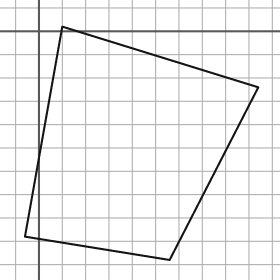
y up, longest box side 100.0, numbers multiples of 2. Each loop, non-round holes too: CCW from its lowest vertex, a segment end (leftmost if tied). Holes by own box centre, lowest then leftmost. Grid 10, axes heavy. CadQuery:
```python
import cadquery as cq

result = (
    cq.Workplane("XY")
    .moveTo(56.0, -98.0)
    .lineTo(94.0, -24.0)
    .lineTo(10.0, 2.0)
    .lineTo(-6.0, -88.0)
    .close()
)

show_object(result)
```